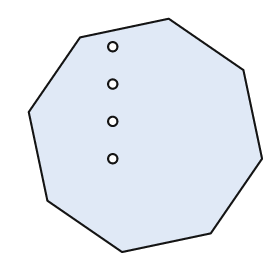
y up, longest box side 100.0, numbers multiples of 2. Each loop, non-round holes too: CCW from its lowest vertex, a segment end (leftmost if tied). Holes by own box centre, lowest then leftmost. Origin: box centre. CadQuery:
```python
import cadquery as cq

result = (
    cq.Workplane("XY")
    .moveTo(-10.0, -50.0)
    .lineTo(28.0, -42.0)
    .lineTo(50.0, -10.0)
    .lineTo(42.0, 28.0)
    .lineTo(10.0, 50.0)
    .lineTo(-28.0, 42.0)
    .lineTo(-50.0, 10.0)
    .lineTo(-42.0, -28.0)
    .close()
    .moveTo(-14.0, -10.0)
    .circle(2.0)
    .moveTo(-14.0, 6.0)
    .circle(2.0)
    .moveTo(-14.0, 22.0)
    .circle(2.0)
    .moveTo(-14.0, 38.0)
    .circle(2.0)
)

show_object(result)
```